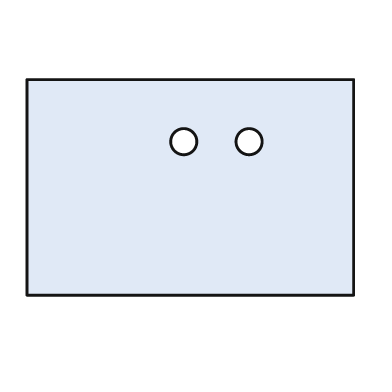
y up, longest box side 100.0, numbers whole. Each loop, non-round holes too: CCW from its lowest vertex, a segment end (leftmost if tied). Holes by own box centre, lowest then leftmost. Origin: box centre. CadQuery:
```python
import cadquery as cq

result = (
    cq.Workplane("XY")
    .moveTo(-50.0, -33.0)
    .lineTo(50.0, -33.0)
    .lineTo(50.0, 33.0)
    .lineTo(-50.0, 33.0)
    .close()
    .moveTo(-2.0, 14.0)
    .circle(4.0)
    .moveTo(18.0, 14.0)
    .circle(4.0)
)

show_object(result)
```